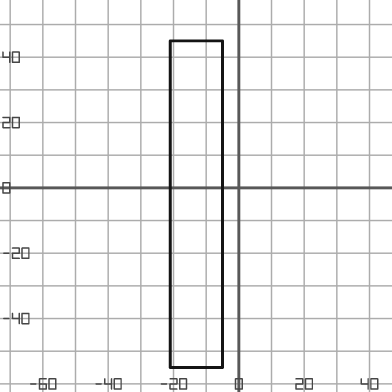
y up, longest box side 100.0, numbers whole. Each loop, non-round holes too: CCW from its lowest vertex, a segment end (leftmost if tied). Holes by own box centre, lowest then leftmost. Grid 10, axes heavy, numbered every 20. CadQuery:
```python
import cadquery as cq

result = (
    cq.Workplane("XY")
    .moveTo(-21.0, -55.0)
    .lineTo(-5.0, -55.0)
    .lineTo(-5.0, 45.0)
    .lineTo(-21.0, 45.0)
    .close()
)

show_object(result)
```